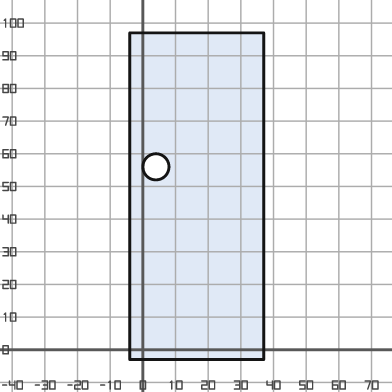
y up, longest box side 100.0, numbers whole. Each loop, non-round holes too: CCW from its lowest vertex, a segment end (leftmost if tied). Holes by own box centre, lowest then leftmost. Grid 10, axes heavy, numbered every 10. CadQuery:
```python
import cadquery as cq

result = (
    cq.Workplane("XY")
    .moveTo(-4.0, -3.0)
    .lineTo(37.0, -3.0)
    .lineTo(37.0, 97.0)
    .lineTo(-4.0, 97.0)
    .close()
    .moveTo(4.0, 56.0)
    .circle(4.0)
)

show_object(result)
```